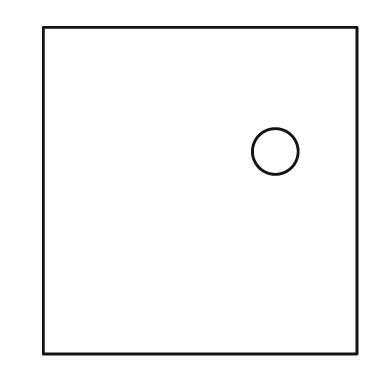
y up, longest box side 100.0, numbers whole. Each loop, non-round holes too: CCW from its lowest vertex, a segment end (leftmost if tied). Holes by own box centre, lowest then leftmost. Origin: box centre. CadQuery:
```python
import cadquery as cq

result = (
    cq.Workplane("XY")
    .moveTo(-48.0, -50.0)
    .lineTo(48.0, -50.0)
    .lineTo(48.0, 50.0)
    .lineTo(-48.0, 50.0)
    .close()
    .moveTo(23.0, 12.0)
    .circle(7.0)
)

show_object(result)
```